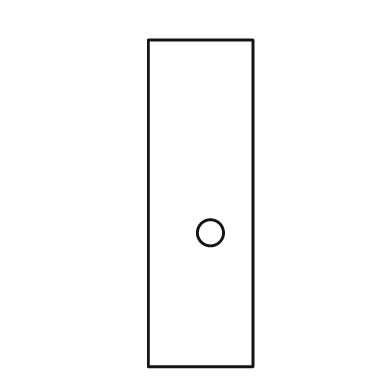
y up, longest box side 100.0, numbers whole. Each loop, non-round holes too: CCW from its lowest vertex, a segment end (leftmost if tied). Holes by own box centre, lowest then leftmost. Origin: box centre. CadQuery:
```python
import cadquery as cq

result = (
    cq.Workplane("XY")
    .moveTo(-16.0, -50.0)
    .lineTo(16.0, -50.0)
    .lineTo(16.0, 50.0)
    .lineTo(-16.0, 50.0)
    .close()
    .moveTo(3.0, -9.0)
    .circle(4.0)
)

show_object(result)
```